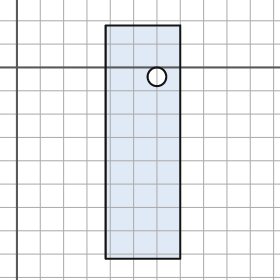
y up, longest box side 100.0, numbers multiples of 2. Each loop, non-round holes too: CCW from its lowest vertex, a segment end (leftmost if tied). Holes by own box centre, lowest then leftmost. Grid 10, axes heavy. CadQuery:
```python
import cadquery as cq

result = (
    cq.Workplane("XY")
    .moveTo(38.0, -82.0)
    .lineTo(70.0, -82.0)
    .lineTo(70.0, 18.0)
    .lineTo(38.0, 18.0)
    .close()
    .moveTo(60.0, -4.0)
    .circle(4.0)
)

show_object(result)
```